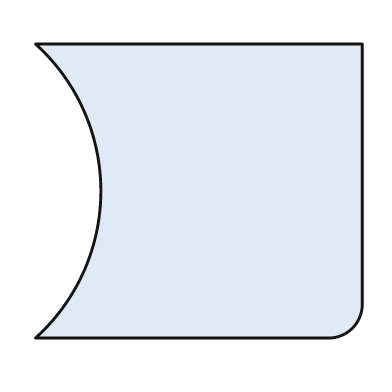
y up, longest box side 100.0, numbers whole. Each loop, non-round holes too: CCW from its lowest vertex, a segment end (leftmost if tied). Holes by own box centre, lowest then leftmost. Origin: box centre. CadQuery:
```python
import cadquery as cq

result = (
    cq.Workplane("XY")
    .moveTo(-50.0, -45.0)
    .lineTo(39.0, -45.0)
    .threePointArc((47.0, -42.0), (50.0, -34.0))
    .lineTo(50.0, 45.0)
    .lineTo(-50.0, 45.0)
    .threePointArc((-30.0, 0.0), (-50.0, -45.0))
    .close()
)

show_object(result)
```